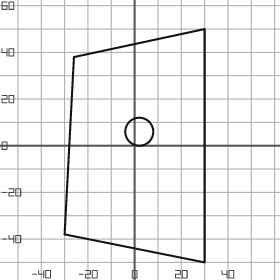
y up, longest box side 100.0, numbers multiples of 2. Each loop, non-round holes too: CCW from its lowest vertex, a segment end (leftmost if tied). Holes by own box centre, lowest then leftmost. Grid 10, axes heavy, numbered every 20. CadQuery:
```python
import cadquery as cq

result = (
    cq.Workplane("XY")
    .moveTo(30.0, -50.0)
    .lineTo(30.0, 50.0)
    .lineTo(-26.0, 38.0)
    .lineTo(-30.0, -38.0)
    .close()
    .moveTo(2.0, 6.0)
    .circle(6.0)
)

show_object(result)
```